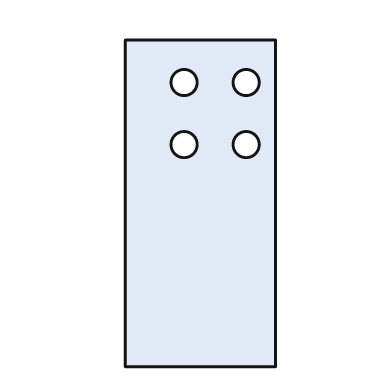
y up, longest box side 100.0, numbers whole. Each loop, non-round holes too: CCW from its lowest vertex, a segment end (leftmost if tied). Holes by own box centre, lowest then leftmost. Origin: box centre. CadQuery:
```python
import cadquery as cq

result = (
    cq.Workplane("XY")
    .moveTo(-23.0, -50.0)
    .lineTo(23.0, -50.0)
    .lineTo(23.0, 50.0)
    .lineTo(-23.0, 50.0)
    .close()
    .moveTo(-5.0, 18.0)
    .circle(4.0)
    .moveTo(14.0, 18.0)
    .circle(4.0)
    .moveTo(-5.0, 37.0)
    .circle(4.0)
    .moveTo(14.0, 37.0)
    .circle(4.0)
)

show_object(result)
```